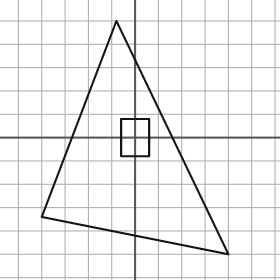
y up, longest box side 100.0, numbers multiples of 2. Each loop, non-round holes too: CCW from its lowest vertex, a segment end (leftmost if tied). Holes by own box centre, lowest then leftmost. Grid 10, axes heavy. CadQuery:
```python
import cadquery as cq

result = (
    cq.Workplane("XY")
    .moveTo(40.0, -50.0)
    .lineTo(-8.0, 50.0)
    .lineTo(-40.0, -34.0)
    .close()
    .moveTo(-6.0, -8.0)
    .lineTo(6.0, -8.0)
    .lineTo(6.0, 8.0)
    .lineTo(-6.0, 8.0)
    .close()
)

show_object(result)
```